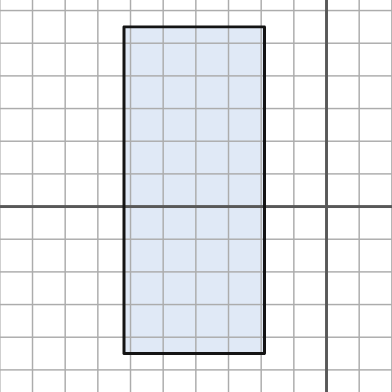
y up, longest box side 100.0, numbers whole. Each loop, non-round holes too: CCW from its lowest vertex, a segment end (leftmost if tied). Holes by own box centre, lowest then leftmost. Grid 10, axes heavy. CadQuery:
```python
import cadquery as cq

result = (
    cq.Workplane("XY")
    .moveTo(-62.0, -45.0)
    .lineTo(-19.0, -45.0)
    .lineTo(-19.0, 55.0)
    .lineTo(-62.0, 55.0)
    .close()
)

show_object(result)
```